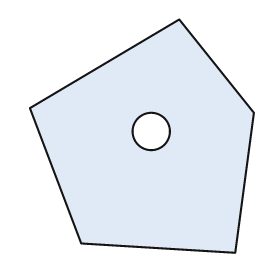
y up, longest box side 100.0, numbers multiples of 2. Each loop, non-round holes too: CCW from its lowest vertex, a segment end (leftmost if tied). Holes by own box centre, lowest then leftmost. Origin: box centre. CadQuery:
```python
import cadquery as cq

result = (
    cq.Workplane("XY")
    .moveTo(40.0, -50.0)
    .lineTo(48.0, 10.0)
    .lineTo(16.0, 50.0)
    .lineTo(-48.0, 12.0)
    .lineTo(-26.0, -46.0)
    .close()
    .moveTo(4.0, 2.0)
    .circle(8.0)
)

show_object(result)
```